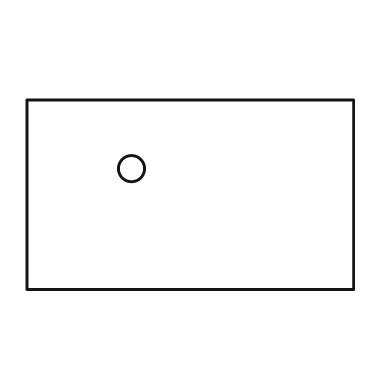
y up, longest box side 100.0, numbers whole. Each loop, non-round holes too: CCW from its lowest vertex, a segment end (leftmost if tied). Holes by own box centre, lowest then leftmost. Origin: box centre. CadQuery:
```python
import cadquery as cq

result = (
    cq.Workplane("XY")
    .moveTo(-50.0, -29.0)
    .lineTo(50.0, -29.0)
    .lineTo(50.0, 29.0)
    .lineTo(-50.0, 29.0)
    .close()
    .moveTo(-18.0, 8.0)
    .circle(4.0)
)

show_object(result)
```